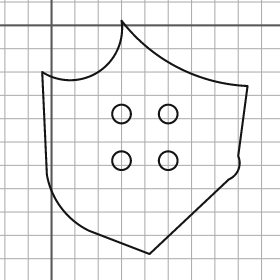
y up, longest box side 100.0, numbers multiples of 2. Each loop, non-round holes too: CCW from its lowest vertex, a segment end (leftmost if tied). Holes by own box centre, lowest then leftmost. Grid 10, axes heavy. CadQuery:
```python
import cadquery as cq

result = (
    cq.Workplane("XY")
    .moveTo(42.0, -98.0)
    .lineTo(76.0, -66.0)
    .threePointArc((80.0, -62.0), (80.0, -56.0))
    .lineTo(84.0, -26.0)
    .threePointArc((54.0, -18.0), (30.0, 2.0))
    .threePointArc((20.0, -20.0), (-4.0, -20.0))
    .lineTo(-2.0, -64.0)
    .threePointArc((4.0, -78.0), (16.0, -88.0))
    .close()
    .moveTo(30.0, -58.0)
    .circle(4.0)
    .moveTo(50.0, -58.0)
    .circle(4.0)
    .moveTo(30.0, -38.0)
    .circle(4.0)
    .moveTo(50.0, -38.0)
    .circle(4.0)
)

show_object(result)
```